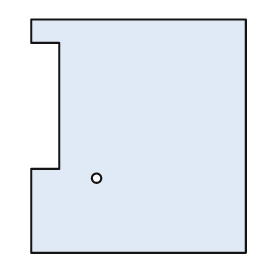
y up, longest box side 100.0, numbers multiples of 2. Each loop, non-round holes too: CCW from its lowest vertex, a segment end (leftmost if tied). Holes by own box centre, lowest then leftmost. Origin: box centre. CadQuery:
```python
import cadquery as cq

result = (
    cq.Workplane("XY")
    .moveTo(-46.0, -50.0)
    .lineTo(46.0, -50.0)
    .lineTo(46.0, 50.0)
    .lineTo(-46.0, 50.0)
    .lineTo(-46.0, 40.0)
    .lineTo(-34.0, 40.0)
    .lineTo(-34.0, -14.0)
    .lineTo(-46.0, -14.0)
    .close()
    .moveTo(-18.0, -18.0)
    .circle(2.0)
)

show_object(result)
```